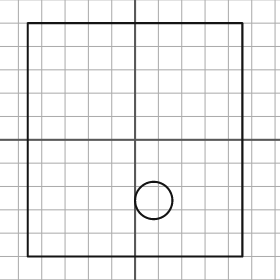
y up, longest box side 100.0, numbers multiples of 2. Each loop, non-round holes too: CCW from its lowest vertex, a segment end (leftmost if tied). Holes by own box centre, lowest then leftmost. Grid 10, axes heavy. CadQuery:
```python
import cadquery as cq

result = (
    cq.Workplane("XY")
    .moveTo(-46.0, -50.0)
    .lineTo(46.0, -50.0)
    .lineTo(46.0, 50.0)
    .lineTo(-46.0, 50.0)
    .close()
    .moveTo(8.0, -26.0)
    .circle(8.0)
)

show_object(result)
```